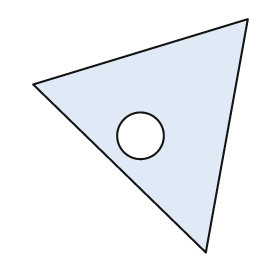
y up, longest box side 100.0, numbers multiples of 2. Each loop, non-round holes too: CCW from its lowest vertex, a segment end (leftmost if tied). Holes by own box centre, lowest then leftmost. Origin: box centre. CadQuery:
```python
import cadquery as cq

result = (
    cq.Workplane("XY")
    .moveTo(28.0, -50.0)
    .lineTo(46.0, 50.0)
    .lineTo(-46.0, 22.0)
    .close()
    .moveTo(0.0, 0.0)
    .circle(10.0)
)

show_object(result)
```